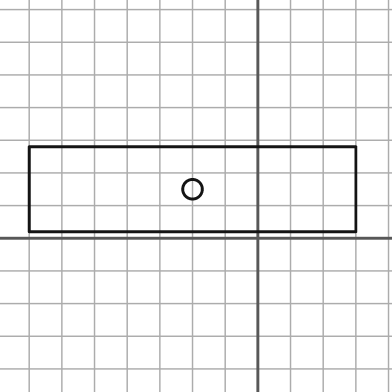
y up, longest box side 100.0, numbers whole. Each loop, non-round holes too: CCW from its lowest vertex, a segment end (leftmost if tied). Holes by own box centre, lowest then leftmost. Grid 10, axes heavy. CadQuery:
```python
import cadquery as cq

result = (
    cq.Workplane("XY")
    .moveTo(-70.0, 2.0)
    .lineTo(30.0, 2.0)
    .lineTo(30.0, 28.0)
    .lineTo(-70.0, 28.0)
    .close()
    .moveTo(-20.0, 15.0)
    .circle(3.0)
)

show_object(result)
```